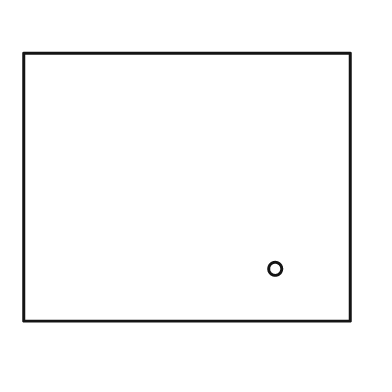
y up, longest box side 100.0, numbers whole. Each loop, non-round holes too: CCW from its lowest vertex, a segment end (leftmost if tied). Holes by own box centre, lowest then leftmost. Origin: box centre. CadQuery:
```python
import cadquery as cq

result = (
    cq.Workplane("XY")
    .moveTo(-50.0, -41.0)
    .lineTo(50.0, -41.0)
    .lineTo(50.0, 41.0)
    .lineTo(-50.0, 41.0)
    .close()
    .moveTo(27.0, -25.0)
    .circle(2.0)
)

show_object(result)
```